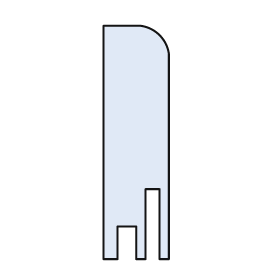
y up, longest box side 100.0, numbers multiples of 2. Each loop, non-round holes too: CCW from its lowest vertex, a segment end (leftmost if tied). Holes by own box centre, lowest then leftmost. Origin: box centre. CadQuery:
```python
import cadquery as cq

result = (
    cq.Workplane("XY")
    .moveTo(-14.0, -50.0)
    .lineTo(-8.0, -50.0)
    .lineTo(-8.0, -36.0)
    .lineTo(0.0, -36.0)
    .lineTo(0.0, -50.0)
    .lineTo(4.0, -50.0)
    .lineTo(4.0, -20.0)
    .lineTo(10.0, -20.0)
    .lineTo(10.0, -50.0)
    .lineTo(14.0, -50.0)
    .lineTo(14.0, 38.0)
    .threePointArc((10.0, 46.0), (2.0, 50.0))
    .lineTo(-14.0, 50.0)
    .close()
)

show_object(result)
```